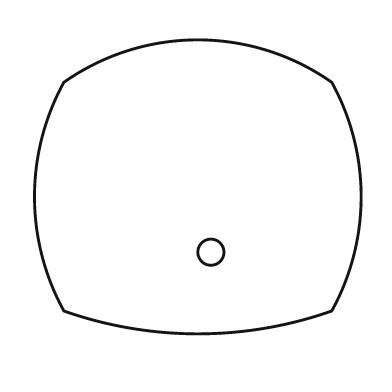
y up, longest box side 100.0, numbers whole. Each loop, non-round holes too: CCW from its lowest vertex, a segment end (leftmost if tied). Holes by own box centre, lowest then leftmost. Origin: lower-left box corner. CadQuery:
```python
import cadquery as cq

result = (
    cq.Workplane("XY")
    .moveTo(9.0, 7.0)
    .threePointArc((50.0, 0.0), (91.0, 7.0))
    .threePointArc((100.0, 42.0), (91.0, 77.0))
    .threePointArc((50.0, 90.0), (9.0, 77.0))
    .threePointArc((0.0, 42.0), (9.0, 7.0))
    .close()
    .moveTo(54.0, 25.0)
    .circle(4.0)
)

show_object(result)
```